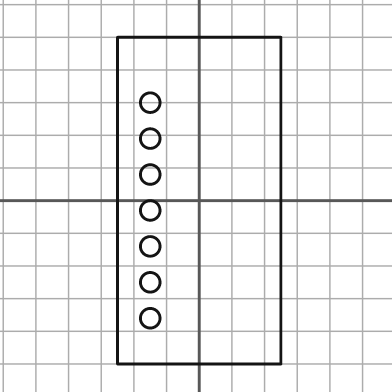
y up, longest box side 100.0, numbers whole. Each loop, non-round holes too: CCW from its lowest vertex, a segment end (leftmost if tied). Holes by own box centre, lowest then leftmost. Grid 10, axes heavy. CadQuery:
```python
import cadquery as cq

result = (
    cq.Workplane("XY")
    .moveTo(-25.0, -50.0)
    .lineTo(25.0, -50.0)
    .lineTo(25.0, 50.0)
    .lineTo(-25.0, 50.0)
    .close()
    .moveTo(-15.0, -36.0)
    .circle(3.0)
    .moveTo(-15.0, -25.0)
    .circle(3.0)
    .moveTo(-15.0, -14.0)
    .circle(3.0)
    .moveTo(-15.0, -3.0)
    .circle(3.0)
    .moveTo(-15.0, 8.0)
    .circle(3.0)
    .moveTo(-15.0, 19.0)
    .circle(3.0)
    .moveTo(-15.0, 30.0)
    .circle(3.0)
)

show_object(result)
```